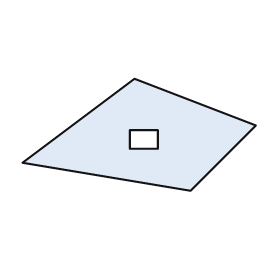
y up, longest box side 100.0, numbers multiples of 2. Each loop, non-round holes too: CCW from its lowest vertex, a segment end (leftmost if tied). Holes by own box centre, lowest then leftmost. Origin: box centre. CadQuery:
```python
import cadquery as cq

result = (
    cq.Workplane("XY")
    .moveTo(22.0, -24.0)
    .lineTo(50.0, 4.0)
    .lineTo(-2.0, 24.0)
    .lineTo(-50.0, -12.0)
    .close()
    .moveTo(-4.0, -6.0)
    .lineTo(8.0, -6.0)
    .lineTo(8.0, 2.0)
    .lineTo(-4.0, 2.0)
    .close()
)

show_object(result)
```